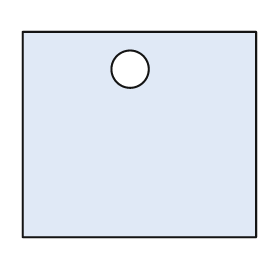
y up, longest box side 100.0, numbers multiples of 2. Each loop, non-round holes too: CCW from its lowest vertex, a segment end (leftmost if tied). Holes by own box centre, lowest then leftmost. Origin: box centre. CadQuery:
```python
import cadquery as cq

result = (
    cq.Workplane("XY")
    .moveTo(-50.0, -44.0)
    .lineTo(50.0, -44.0)
    .lineTo(50.0, 44.0)
    .lineTo(-50.0, 44.0)
    .close()
    .moveTo(-4.0, 28.0)
    .circle(8.0)
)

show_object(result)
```